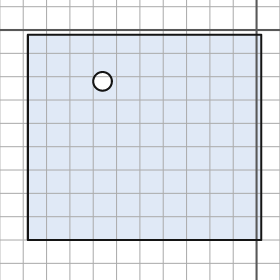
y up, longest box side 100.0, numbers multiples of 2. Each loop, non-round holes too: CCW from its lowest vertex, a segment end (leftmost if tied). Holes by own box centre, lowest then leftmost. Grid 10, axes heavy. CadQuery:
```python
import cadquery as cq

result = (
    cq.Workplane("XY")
    .moveTo(-98.0, -90.0)
    .lineTo(2.0, -90.0)
    .lineTo(2.0, -2.0)
    .lineTo(-98.0, -2.0)
    .close()
    .moveTo(-66.0, -22.0)
    .circle(4.0)
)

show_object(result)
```